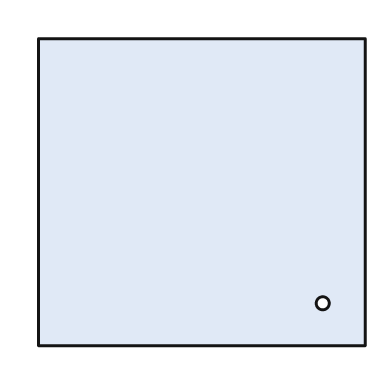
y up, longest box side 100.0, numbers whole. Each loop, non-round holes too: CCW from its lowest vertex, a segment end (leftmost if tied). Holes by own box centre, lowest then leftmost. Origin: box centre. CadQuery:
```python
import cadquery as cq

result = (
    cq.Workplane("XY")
    .moveTo(-50.0, -47.0)
    .lineTo(50.0, -47.0)
    .lineTo(50.0, 47.0)
    .lineTo(-50.0, 47.0)
    .close()
    .moveTo(37.0, -34.0)
    .circle(2.0)
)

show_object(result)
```